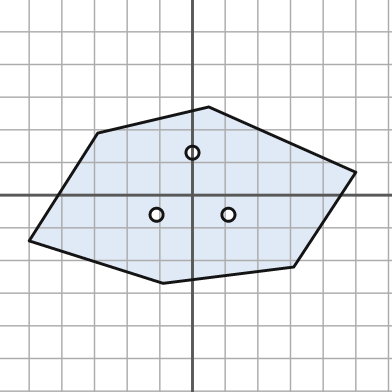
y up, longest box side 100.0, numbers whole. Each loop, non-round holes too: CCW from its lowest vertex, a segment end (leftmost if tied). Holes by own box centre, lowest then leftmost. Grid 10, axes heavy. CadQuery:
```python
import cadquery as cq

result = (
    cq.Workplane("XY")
    .moveTo(-9.0, -27.0)
    .lineTo(31.0, -22.0)
    .lineTo(50.0, 7.0)
    .lineTo(5.0, 27.0)
    .lineTo(-29.0, 19.0)
    .lineTo(-50.0, -14.0)
    .close()
    .moveTo(-11.0, -6.0)
    .circle(2.0)
    .moveTo(11.0, -6.0)
    .circle(2.0)
    .moveTo(0.0, 13.0)
    .circle(2.0)
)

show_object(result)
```